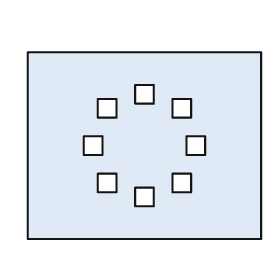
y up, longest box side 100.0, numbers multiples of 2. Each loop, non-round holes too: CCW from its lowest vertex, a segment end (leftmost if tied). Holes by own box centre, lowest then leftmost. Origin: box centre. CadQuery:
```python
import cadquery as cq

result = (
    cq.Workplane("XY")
    .moveTo(-50.0, -40.0)
    .lineTo(50.0, -40.0)
    .lineTo(50.0, 40.0)
    .lineTo(-50.0, 40.0)
    .close()
    .moveTo(-4.0, -26.0)
    .lineTo(4.0, -26.0)
    .lineTo(4.0, -18.0)
    .lineTo(-4.0, -18.0)
    .close()
    .moveTo(-20.0, -20.0)
    .lineTo(-12.0, -20.0)
    .lineTo(-12.0, -12.0)
    .lineTo(-20.0, -12.0)
    .close()
    .moveTo(12.0, -20.0)
    .lineTo(20.0, -20.0)
    .lineTo(20.0, -12.0)
    .lineTo(12.0, -12.0)
    .close()
    .moveTo(-26.0, -4.0)
    .lineTo(-18.0, -4.0)
    .lineTo(-18.0, 4.0)
    .lineTo(-26.0, 4.0)
    .close()
    .moveTo(18.0, -4.0)
    .lineTo(26.0, -4.0)
    .lineTo(26.0, 4.0)
    .lineTo(18.0, 4.0)
    .close()
    .moveTo(-20.0, 12.0)
    .lineTo(-12.0, 12.0)
    .lineTo(-12.0, 20.0)
    .lineTo(-20.0, 20.0)
    .close()
    .moveTo(12.0, 12.0)
    .lineTo(20.0, 12.0)
    .lineTo(20.0, 20.0)
    .lineTo(12.0, 20.0)
    .close()
    .moveTo(-4.0, 18.0)
    .lineTo(4.0, 18.0)
    .lineTo(4.0, 26.0)
    .lineTo(-4.0, 26.0)
    .close()
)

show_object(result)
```